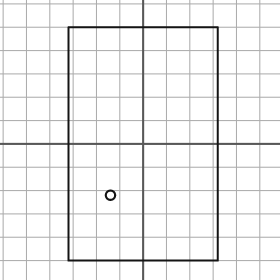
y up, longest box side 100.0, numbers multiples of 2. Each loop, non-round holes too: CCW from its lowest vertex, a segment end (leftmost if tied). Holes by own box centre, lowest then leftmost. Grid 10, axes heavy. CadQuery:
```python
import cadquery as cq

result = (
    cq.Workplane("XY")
    .moveTo(-32.0, -50.0)
    .lineTo(32.0, -50.0)
    .lineTo(32.0, 50.0)
    .lineTo(-32.0, 50.0)
    .close()
    .moveTo(-14.0, -22.0)
    .circle(2.0)
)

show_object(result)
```